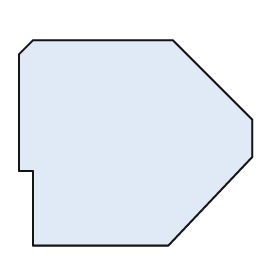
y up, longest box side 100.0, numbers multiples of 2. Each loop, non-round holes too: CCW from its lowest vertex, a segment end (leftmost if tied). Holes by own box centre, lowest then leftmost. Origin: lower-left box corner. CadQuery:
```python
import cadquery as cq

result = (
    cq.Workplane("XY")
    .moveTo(6.0, 0.0)
    .lineTo(64.0, 0.0)
    .lineTo(100.0, 38.0)
    .lineTo(100.0, 54.0)
    .lineTo(66.0, 88.0)
    .lineTo(6.0, 88.0)
    .lineTo(0.0, 82.0)
    .lineTo(0.0, 32.0)
    .lineTo(6.0, 32.0)
    .close()
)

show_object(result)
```